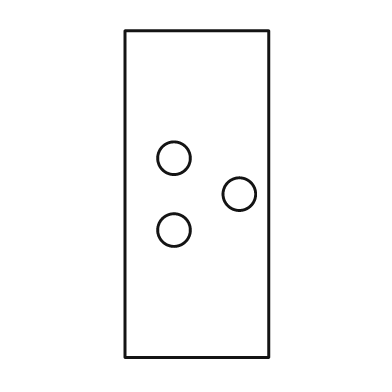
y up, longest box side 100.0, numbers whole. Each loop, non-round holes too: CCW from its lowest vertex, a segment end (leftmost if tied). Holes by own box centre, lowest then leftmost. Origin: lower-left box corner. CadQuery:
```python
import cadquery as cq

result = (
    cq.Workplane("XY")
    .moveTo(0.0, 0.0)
    .lineTo(44.0, 0.0)
    .lineTo(44.0, 100.0)
    .lineTo(0.0, 100.0)
    .close()
    .moveTo(15.0, 39.0)
    .circle(5.0)
    .moveTo(35.0, 50.0)
    .circle(5.0)
    .moveTo(15.0, 61.0)
    .circle(5.0)
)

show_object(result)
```